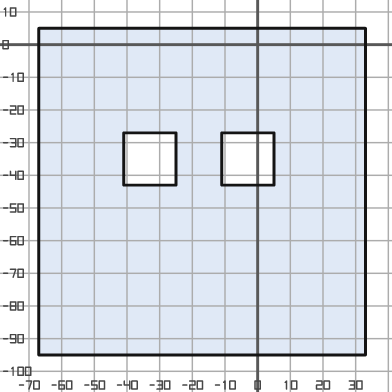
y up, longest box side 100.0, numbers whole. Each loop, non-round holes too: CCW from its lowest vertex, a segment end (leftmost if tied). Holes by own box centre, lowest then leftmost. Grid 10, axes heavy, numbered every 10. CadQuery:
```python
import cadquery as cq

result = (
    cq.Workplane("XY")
    .moveTo(-67.0, -95.0)
    .lineTo(33.0, -95.0)
    .lineTo(33.0, 5.0)
    .lineTo(-67.0, 5.0)
    .close()
    .moveTo(-41.0, -43.0)
    .lineTo(-25.0, -43.0)
    .lineTo(-25.0, -27.0)
    .lineTo(-41.0, -27.0)
    .close()
    .moveTo(-11.0, -43.0)
    .lineTo(5.0, -43.0)
    .lineTo(5.0, -27.0)
    .lineTo(-11.0, -27.0)
    .close()
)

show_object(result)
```